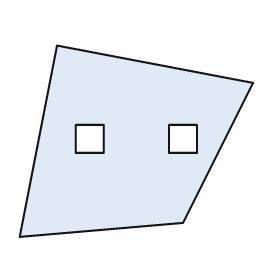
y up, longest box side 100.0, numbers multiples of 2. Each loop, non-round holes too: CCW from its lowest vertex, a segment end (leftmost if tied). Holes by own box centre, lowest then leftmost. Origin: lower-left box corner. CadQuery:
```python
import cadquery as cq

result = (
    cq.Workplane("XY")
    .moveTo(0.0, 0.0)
    .lineTo(70.0, 6.0)
    .lineTo(100.0, 66.0)
    .lineTo(16.0, 82.0)
    .close()
    .moveTo(24.0, 36.0)
    .lineTo(36.0, 36.0)
    .lineTo(36.0, 48.0)
    .lineTo(24.0, 48.0)
    .close()
    .moveTo(64.0, 36.0)
    .lineTo(76.0, 36.0)
    .lineTo(76.0, 48.0)
    .lineTo(64.0, 48.0)
    .close()
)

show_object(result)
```